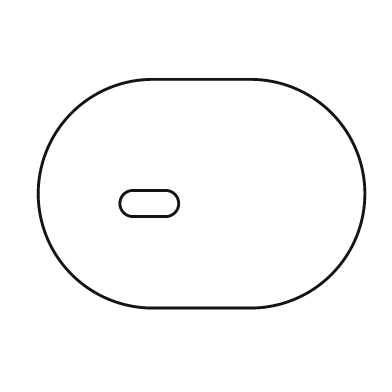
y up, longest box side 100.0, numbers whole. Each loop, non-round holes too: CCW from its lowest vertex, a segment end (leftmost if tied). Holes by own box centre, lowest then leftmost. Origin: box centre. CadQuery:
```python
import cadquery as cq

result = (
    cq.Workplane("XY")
    .moveTo(-15.0, -35.0)
    .lineTo(15.0, -35.0)
    .threePointArc((50.0, 0.0), (15.0, 35.0))
    .lineTo(-15.0, 35.0)
    .threePointArc((-50.0, 0.0), (-15.0, -35.0))
    .close()
    .moveTo(-21.0, -7.0)
    .lineTo(-11.0, -7.0)
    .threePointArc((-7.0, -3.0), (-11.0, 1.0))
    .lineTo(-21.0, 1.0)
    .threePointArc((-25.0, -3.0), (-21.0, -7.0))
    .close()
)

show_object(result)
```